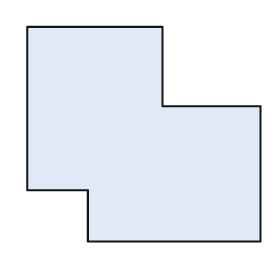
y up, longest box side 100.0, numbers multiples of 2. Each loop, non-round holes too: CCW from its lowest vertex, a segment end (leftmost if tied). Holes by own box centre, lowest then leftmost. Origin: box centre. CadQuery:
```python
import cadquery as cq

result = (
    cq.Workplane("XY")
    .moveTo(-24.0, -46.0)
    .lineTo(50.0, -46.0)
    .lineTo(50.0, 12.0)
    .lineTo(8.0, 12.0)
    .lineTo(8.0, 46.0)
    .lineTo(-50.0, 46.0)
    .lineTo(-50.0, -24.0)
    .lineTo(-24.0, -24.0)
    .close()
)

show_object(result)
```